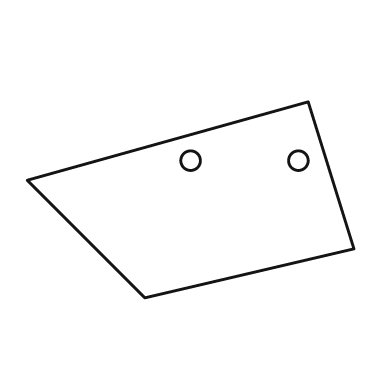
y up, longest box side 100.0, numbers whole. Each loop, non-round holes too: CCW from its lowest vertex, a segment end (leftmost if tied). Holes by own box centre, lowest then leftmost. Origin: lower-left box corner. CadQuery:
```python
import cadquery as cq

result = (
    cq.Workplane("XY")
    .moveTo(36.0, 0.0)
    .lineTo(100.0, 15.0)
    .lineTo(86.0, 60.0)
    .lineTo(0.0, 36.0)
    .close()
    .moveTo(50.0, 42.0)
    .circle(3.0)
    .moveTo(83.0, 42.0)
    .circle(3.0)
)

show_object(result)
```